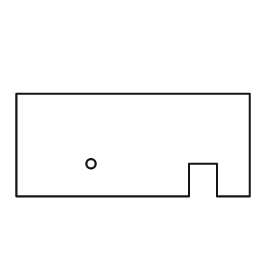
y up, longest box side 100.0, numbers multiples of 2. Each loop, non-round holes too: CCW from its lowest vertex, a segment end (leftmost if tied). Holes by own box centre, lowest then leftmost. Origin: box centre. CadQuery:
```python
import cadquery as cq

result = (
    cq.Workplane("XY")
    .moveTo(-50.0, -22.0)
    .lineTo(24.0, -22.0)
    .lineTo(24.0, -8.0)
    .lineTo(36.0, -8.0)
    .lineTo(36.0, -22.0)
    .lineTo(50.0, -22.0)
    .lineTo(50.0, 22.0)
    .lineTo(-50.0, 22.0)
    .close()
    .moveTo(-18.0, -8.0)
    .circle(2.0)
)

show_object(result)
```